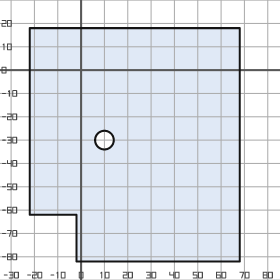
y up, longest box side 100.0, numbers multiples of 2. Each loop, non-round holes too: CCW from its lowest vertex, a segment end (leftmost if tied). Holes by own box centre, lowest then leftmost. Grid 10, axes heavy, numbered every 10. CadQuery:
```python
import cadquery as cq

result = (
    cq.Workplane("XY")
    .moveTo(-2.0, -82.0)
    .lineTo(68.0, -82.0)
    .lineTo(68.0, 18.0)
    .lineTo(-22.0, 18.0)
    .lineTo(-22.0, -62.0)
    .lineTo(-2.0, -62.0)
    .close()
    .moveTo(10.0, -30.0)
    .circle(4.0)
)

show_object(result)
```